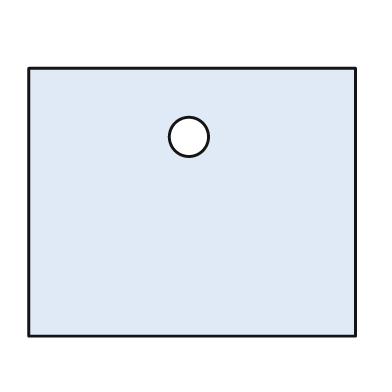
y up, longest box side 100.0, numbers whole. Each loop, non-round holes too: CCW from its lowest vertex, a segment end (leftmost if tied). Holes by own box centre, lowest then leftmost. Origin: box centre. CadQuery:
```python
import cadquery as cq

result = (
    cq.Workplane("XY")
    .moveTo(-50.0, -41.0)
    .lineTo(50.0, -41.0)
    .lineTo(50.0, 41.0)
    .lineTo(-50.0, 41.0)
    .close()
    .moveTo(-1.0, 20.0)
    .circle(6.0)
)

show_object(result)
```